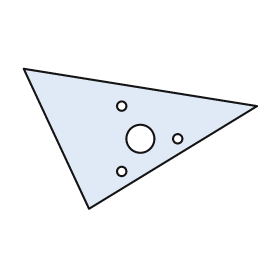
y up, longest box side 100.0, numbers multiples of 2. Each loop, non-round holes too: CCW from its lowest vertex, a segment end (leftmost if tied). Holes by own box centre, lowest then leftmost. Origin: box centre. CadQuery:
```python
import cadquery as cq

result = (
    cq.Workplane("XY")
    .moveTo(-22.0, -30.0)
    .lineTo(50.0, 14.0)
    .lineTo(-50.0, 30.0)
    .close()
    .moveTo(-8.0, -14.0)
    .circle(2.0)
    .moveTo(0.0, 0.0)
    .circle(6.0)
    .moveTo(16.0, 0.0)
    .circle(2.0)
    .moveTo(-8.0, 14.0)
    .circle(2.0)
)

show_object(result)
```